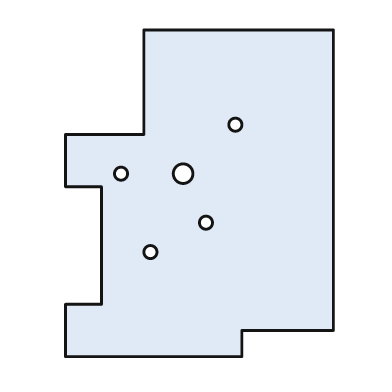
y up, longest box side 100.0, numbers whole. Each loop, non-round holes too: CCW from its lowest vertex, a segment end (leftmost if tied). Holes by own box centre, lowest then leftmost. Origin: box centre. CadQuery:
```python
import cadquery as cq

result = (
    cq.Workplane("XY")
    .moveTo(-41.0, -50.0)
    .lineTo(13.0, -50.0)
    .lineTo(13.0, -42.0)
    .lineTo(41.0, -42.0)
    .lineTo(41.0, 50.0)
    .lineTo(-17.0, 50.0)
    .lineTo(-17.0, 18.0)
    .lineTo(-41.0, 18.0)
    .lineTo(-41.0, 2.0)
    .lineTo(-30.0, 2.0)
    .lineTo(-30.0, -34.0)
    .lineTo(-41.0, -34.0)
    .close()
    .moveTo(-15.0, -18.0)
    .circle(2.0)
    .moveTo(2.0, -9.0)
    .circle(2.0)
    .moveTo(-24.0, 6.0)
    .circle(2.0)
    .moveTo(-5.0, 6.0)
    .circle(3.0)
    .moveTo(11.0, 21.0)
    .circle(2.0)
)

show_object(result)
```